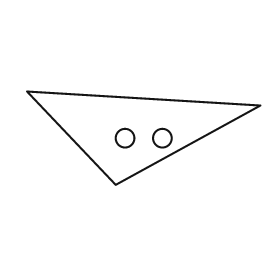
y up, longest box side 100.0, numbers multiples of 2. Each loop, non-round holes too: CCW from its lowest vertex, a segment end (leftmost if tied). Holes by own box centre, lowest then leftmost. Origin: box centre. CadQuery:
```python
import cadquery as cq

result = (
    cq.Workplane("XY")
    .moveTo(-12.0, -20.0)
    .lineTo(50.0, 14.0)
    .lineTo(-50.0, 20.0)
    .close()
    .moveTo(-8.0, 0.0)
    .circle(4.0)
    .moveTo(8.0, 0.0)
    .circle(4.0)
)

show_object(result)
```